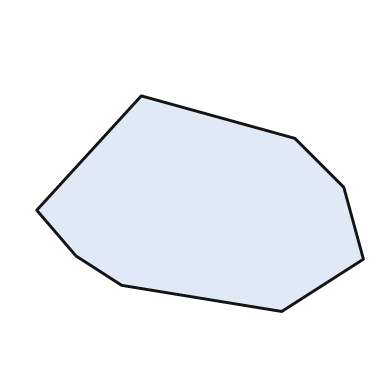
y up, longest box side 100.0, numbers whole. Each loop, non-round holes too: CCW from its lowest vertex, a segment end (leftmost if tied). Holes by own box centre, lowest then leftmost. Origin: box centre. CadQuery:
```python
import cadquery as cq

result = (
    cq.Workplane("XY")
    .moveTo(25.0, -33.0)
    .lineTo(50.0, -17.0)
    .lineTo(44.0, 5.0)
    .lineTo(29.0, 20.0)
    .lineTo(-18.0, 33.0)
    .lineTo(-50.0, -2.0)
    .lineTo(-38.0, -16.0)
    .lineTo(-24.0, -25.0)
    .close()
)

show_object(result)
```